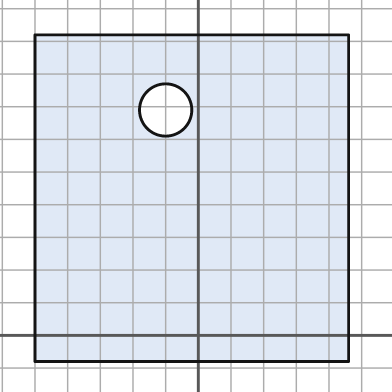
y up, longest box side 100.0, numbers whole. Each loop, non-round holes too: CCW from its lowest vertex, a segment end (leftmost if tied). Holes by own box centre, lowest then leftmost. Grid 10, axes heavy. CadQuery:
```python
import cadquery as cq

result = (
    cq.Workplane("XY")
    .moveTo(-50.0, -8.0)
    .lineTo(46.0, -8.0)
    .lineTo(46.0, 92.0)
    .lineTo(-50.0, 92.0)
    .close()
    .moveTo(-10.0, 69.0)
    .circle(8.0)
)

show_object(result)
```